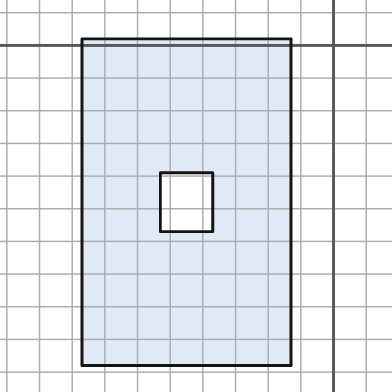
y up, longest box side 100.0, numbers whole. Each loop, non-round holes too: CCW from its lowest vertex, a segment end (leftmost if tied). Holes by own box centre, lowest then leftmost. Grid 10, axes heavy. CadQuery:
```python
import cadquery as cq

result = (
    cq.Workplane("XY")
    .moveTo(-77.0, -98.0)
    .lineTo(-13.0, -98.0)
    .lineTo(-13.0, 2.0)
    .lineTo(-77.0, 2.0)
    .close()
    .moveTo(-53.0, -57.0)
    .lineTo(-37.0, -57.0)
    .lineTo(-37.0, -39.0)
    .lineTo(-53.0, -39.0)
    .close()
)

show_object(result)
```